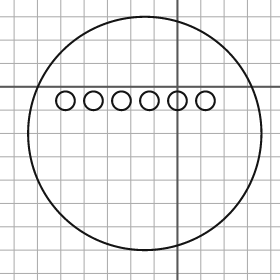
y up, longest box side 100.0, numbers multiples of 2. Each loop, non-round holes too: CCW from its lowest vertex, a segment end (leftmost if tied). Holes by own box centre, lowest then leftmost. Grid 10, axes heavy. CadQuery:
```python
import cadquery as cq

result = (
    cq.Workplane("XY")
    .moveTo(-14.0, -20.0)
    .circle(50.0)
    .moveTo(-48.0, -6.0)
    .circle(4.0)
    .moveTo(-36.0, -6.0)
    .circle(4.0)
    .moveTo(-24.0, -6.0)
    .circle(4.0)
    .moveTo(-12.0, -6.0)
    .circle(4.0)
    .moveTo(0.0, -6.0)
    .circle(4.0)
    .moveTo(12.0, -6.0)
    .circle(4.0)
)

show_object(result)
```